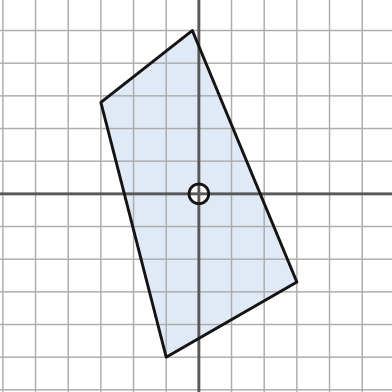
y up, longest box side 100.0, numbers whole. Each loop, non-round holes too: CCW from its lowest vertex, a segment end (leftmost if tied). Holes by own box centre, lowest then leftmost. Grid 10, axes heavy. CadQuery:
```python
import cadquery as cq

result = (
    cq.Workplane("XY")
    .moveTo(-10.0, -50.0)
    .lineTo(30.0, -27.0)
    .lineTo(-2.0, 50.0)
    .lineTo(-30.0, 28.0)
    .close()
    .moveTo(0.0, 0.0)
    .circle(3.0)
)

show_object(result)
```